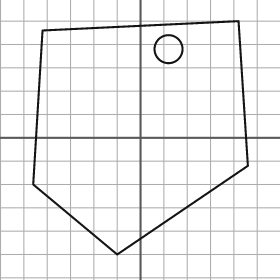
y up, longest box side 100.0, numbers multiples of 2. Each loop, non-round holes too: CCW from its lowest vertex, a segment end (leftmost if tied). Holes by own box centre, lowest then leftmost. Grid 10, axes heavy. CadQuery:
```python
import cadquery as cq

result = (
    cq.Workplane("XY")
    .moveTo(-10.0, -50.0)
    .lineTo(46.0, -12.0)
    .lineTo(42.0, 50.0)
    .lineTo(-42.0, 46.0)
    .lineTo(-46.0, -20.0)
    .close()
    .moveTo(12.0, 38.0)
    .circle(6.0)
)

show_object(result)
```